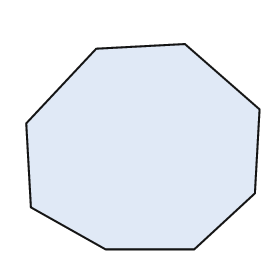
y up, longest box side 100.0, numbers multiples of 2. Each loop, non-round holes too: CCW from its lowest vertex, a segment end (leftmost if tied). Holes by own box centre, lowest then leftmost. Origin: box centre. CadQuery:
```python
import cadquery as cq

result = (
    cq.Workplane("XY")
    .moveTo(-16.0, -44.0)
    .lineTo(22.0, -44.0)
    .lineTo(48.0, -20.0)
    .lineTo(50.0, 16.0)
    .lineTo(18.0, 44.0)
    .lineTo(-20.0, 42.0)
    .lineTo(-50.0, 10.0)
    .lineTo(-48.0, -26.0)
    .close()
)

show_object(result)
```